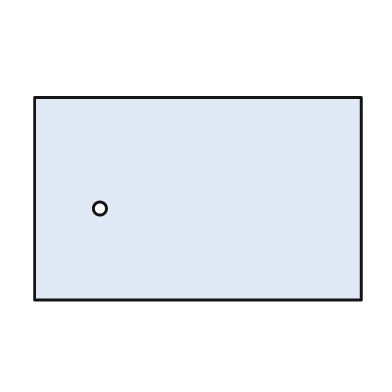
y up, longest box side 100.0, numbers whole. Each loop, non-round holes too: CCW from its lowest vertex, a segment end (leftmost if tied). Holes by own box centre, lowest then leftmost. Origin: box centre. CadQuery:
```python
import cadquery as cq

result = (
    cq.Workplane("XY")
    .moveTo(-50.0, -31.0)
    .lineTo(50.0, -31.0)
    .lineTo(50.0, 31.0)
    .lineTo(-50.0, 31.0)
    .close()
    .moveTo(-30.0, -3.0)
    .circle(2.0)
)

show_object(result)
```